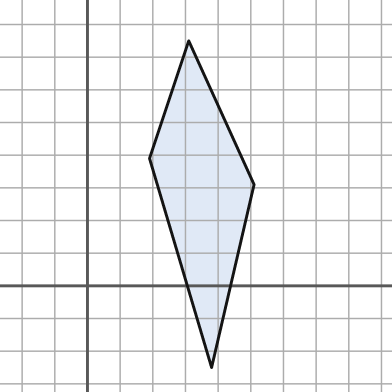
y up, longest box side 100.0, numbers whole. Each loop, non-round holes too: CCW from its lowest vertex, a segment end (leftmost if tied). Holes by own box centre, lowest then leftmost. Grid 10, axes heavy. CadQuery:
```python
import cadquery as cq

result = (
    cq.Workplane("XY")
    .moveTo(38.0, -25.0)
    .lineTo(51.0, 31.0)
    .lineTo(31.0, 75.0)
    .lineTo(19.0, 39.0)
    .close()
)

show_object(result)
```